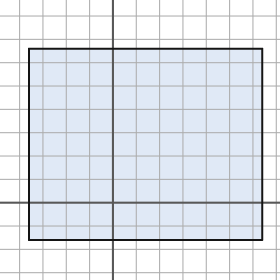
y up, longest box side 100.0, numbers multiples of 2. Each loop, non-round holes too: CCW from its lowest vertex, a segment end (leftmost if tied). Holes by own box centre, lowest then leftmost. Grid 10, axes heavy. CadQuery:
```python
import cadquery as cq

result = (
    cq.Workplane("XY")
    .moveTo(-36.0, -16.0)
    .lineTo(64.0, -16.0)
    .lineTo(64.0, 66.0)
    .lineTo(-36.0, 66.0)
    .close()
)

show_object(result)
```